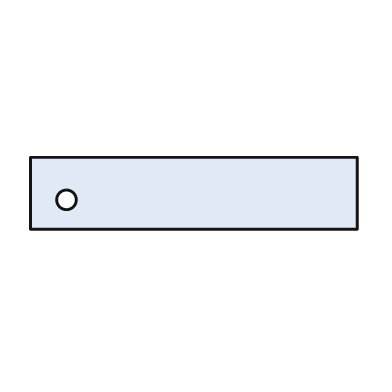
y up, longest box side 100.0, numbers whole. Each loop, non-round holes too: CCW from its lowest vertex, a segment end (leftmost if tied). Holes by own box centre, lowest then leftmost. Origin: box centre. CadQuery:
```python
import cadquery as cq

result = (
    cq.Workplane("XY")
    .moveTo(-50.0, -11.0)
    .lineTo(50.0, -11.0)
    .lineTo(50.0, 11.0)
    .lineTo(-50.0, 11.0)
    .close()
    .moveTo(-39.0, -2.0)
    .circle(3.0)
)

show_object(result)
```